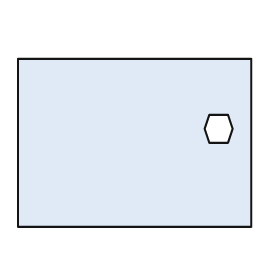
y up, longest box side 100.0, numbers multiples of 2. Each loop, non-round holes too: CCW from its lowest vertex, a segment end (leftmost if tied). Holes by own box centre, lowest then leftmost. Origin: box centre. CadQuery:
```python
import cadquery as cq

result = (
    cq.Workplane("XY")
    .moveTo(-50.0, -36.0)
    .lineTo(50.0, -36.0)
    .lineTo(50.0, 36.0)
    .lineTo(-50.0, 36.0)
    .close()
    .moveTo(32.0, 0.0)
    .lineTo(40.0, 0.0)
    .lineTo(42.0, 6.0)
    .lineTo(40.0, 12.0)
    .lineTo(32.0, 12.0)
    .lineTo(30.0, 6.0)
    .close()
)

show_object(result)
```